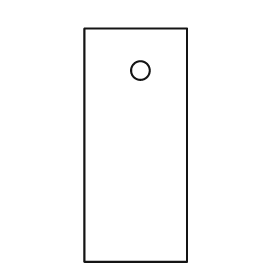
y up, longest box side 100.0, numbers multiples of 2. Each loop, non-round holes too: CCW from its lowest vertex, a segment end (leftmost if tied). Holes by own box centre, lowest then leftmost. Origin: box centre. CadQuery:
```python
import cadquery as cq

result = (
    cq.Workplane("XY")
    .moveTo(-22.0, -50.0)
    .lineTo(22.0, -50.0)
    .lineTo(22.0, 50.0)
    .lineTo(-22.0, 50.0)
    .close()
    .moveTo(2.0, 32.0)
    .circle(4.0)
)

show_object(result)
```